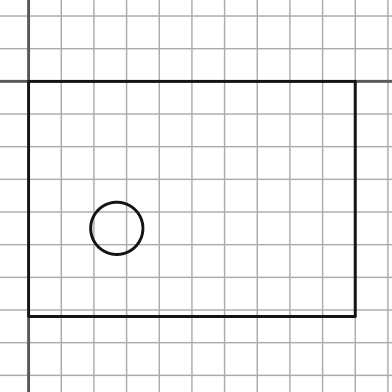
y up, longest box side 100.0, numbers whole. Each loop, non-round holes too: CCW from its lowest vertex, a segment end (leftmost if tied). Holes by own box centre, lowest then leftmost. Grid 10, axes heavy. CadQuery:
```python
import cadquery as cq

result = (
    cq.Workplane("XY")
    .moveTo(0.0, -72.0)
    .lineTo(100.0, -72.0)
    .lineTo(100.0, 0.0)
    .lineTo(0.0, 0.0)
    .close()
    .moveTo(27.0, -45.0)
    .circle(8.0)
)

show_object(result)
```